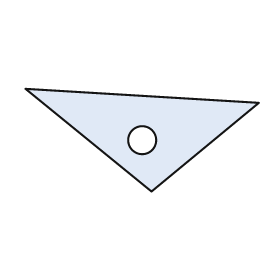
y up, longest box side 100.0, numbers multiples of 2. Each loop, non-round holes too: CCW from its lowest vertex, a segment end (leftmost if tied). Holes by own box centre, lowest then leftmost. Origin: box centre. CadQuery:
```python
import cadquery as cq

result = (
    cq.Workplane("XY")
    .moveTo(4.0, -22.0)
    .lineTo(50.0, 16.0)
    .lineTo(-50.0, 22.0)
    .close()
    .moveTo(0.0, 0.0)
    .circle(6.0)
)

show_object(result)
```